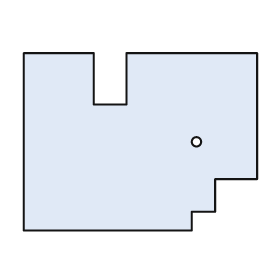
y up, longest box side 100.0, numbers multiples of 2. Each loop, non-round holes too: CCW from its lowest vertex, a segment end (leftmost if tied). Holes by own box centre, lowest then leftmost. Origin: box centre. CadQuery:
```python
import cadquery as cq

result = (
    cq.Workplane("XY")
    .moveTo(-50.0, -38.0)
    .lineTo(22.0, -38.0)
    .lineTo(22.0, -30.0)
    .lineTo(32.0, -30.0)
    .lineTo(32.0, -16.0)
    .lineTo(50.0, -16.0)
    .lineTo(50.0, 38.0)
    .lineTo(-6.0, 38.0)
    .lineTo(-6.0, 16.0)
    .lineTo(-20.0, 16.0)
    .lineTo(-20.0, 38.0)
    .lineTo(-50.0, 38.0)
    .close()
    .moveTo(24.0, 0.0)
    .circle(2.0)
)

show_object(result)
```